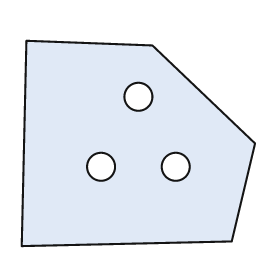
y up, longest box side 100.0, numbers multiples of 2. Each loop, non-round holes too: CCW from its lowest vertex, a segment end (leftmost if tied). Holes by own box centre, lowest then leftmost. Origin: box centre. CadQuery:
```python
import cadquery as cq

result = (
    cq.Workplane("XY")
    .moveTo(-50.0, -44.0)
    .lineTo(40.0, -42.0)
    .lineTo(50.0, 0.0)
    .lineTo(6.0, 42.0)
    .lineTo(-48.0, 44.0)
    .close()
    .moveTo(-16.0, -10.0)
    .circle(6.0)
    .moveTo(16.0, -10.0)
    .circle(6.0)
    .moveTo(0.0, 20.0)
    .circle(6.0)
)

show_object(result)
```